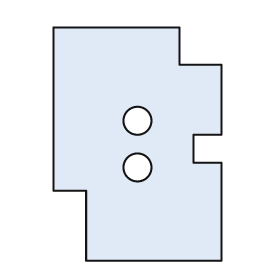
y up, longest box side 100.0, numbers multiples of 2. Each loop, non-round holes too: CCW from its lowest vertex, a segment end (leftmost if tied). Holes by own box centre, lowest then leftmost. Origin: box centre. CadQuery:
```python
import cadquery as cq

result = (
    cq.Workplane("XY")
    .moveTo(-22.0, -50.0)
    .lineTo(36.0, -50.0)
    .lineTo(36.0, -8.0)
    .lineTo(24.0, -8.0)
    .lineTo(24.0, 4.0)
    .lineTo(36.0, 4.0)
    .lineTo(36.0, 34.0)
    .lineTo(18.0, 34.0)
    .lineTo(18.0, 50.0)
    .lineTo(-36.0, 50.0)
    .lineTo(-36.0, -20.0)
    .lineTo(-22.0, -20.0)
    .close()
    .moveTo(0.0, -10.0)
    .circle(6.0)
    .moveTo(0.0, 10.0)
    .circle(6.0)
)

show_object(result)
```